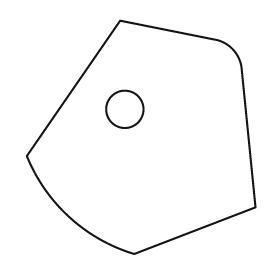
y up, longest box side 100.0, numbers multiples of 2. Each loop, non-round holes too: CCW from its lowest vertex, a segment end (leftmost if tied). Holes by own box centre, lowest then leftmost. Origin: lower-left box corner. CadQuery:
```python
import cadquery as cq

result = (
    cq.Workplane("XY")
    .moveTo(46.0, 0.0)
    .lineTo(98.0, 20.0)
    .lineTo(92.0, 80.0)
    .threePointArc((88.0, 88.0), (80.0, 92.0))
    .lineTo(40.0, 100.0)
    .lineTo(0.0, 42.0)
    .threePointArc((18.0, 16.0), (46.0, 0.0))
    .close()
    .moveTo(42.0, 62.0)
    .circle(8.0)
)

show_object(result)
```